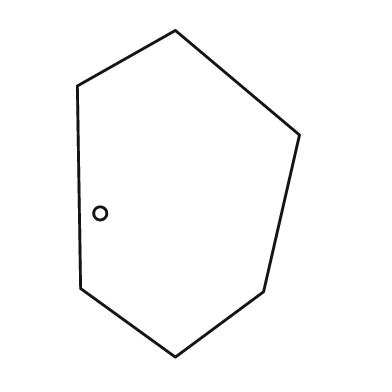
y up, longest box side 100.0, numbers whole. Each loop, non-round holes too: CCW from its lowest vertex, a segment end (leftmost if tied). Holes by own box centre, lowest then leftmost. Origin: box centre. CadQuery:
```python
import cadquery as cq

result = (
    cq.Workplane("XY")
    .moveTo(-4.0, -50.0)
    .lineTo(23.0, -30.0)
    .lineTo(34.0, 18.0)
    .lineTo(-4.0, 50.0)
    .lineTo(-34.0, 33.0)
    .lineTo(-33.0, -29.0)
    .close()
    .moveTo(-27.0, -6.0)
    .circle(2.0)
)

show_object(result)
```